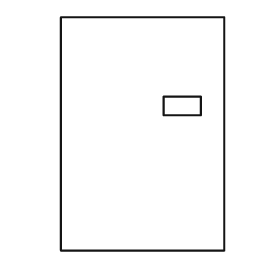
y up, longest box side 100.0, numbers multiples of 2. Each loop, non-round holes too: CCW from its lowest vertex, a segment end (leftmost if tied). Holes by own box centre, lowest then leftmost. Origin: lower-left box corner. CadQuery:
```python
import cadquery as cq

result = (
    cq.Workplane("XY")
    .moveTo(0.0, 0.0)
    .lineTo(70.0, 0.0)
    .lineTo(70.0, 100.0)
    .lineTo(0.0, 100.0)
    .close()
    .moveTo(44.0, 58.0)
    .lineTo(60.0, 58.0)
    .lineTo(60.0, 66.0)
    .lineTo(44.0, 66.0)
    .close()
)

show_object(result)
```